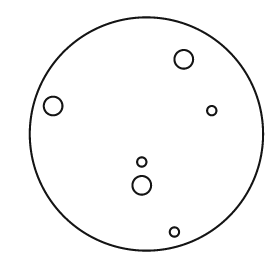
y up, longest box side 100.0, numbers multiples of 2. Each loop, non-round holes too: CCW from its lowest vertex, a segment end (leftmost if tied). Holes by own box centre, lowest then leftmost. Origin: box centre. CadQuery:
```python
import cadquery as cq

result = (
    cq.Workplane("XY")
    .moveTo(0.0, 0.0)
    .circle(50.0)
    .moveTo(12.0, -42.0)
    .circle(2.0)
    .moveTo(-2.0, -22.0)
    .circle(4.0)
    .moveTo(-2.0, -12.0)
    .circle(2.0)
    .moveTo(28.0, 10.0)
    .circle(2.0)
    .moveTo(-40.0, 12.0)
    .circle(4.0)
    .moveTo(16.0, 32.0)
    .circle(4.0)
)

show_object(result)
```